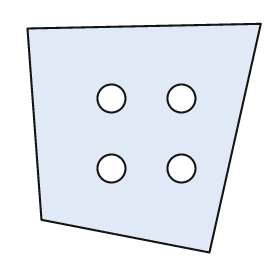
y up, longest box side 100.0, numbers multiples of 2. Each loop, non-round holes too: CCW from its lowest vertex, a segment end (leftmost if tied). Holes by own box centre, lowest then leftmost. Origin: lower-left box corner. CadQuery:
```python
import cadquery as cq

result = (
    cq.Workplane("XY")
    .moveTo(78.0, 0.0)
    .lineTo(100.0, 98.0)
    .lineTo(0.0, 96.0)
    .lineTo(6.0, 14.0)
    .close()
    .moveTo(36.0, 36.0)
    .circle(6.0)
    .moveTo(66.0, 36.0)
    .circle(6.0)
    .moveTo(36.0, 66.0)
    .circle(6.0)
    .moveTo(66.0, 66.0)
    .circle(6.0)
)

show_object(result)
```